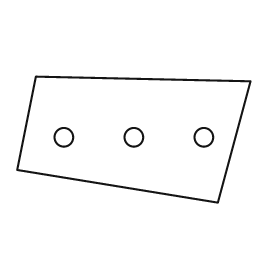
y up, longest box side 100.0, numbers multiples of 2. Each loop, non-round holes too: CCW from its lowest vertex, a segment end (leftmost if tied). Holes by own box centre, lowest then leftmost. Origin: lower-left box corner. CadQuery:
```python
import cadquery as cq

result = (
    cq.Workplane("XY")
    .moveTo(86.0, 0.0)
    .lineTo(100.0, 52.0)
    .lineTo(8.0, 54.0)
    .lineTo(0.0, 14.0)
    .close()
    .moveTo(20.0, 28.0)
    .circle(4.0)
    .moveTo(50.0, 28.0)
    .circle(4.0)
    .moveTo(80.0, 28.0)
    .circle(4.0)
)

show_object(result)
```